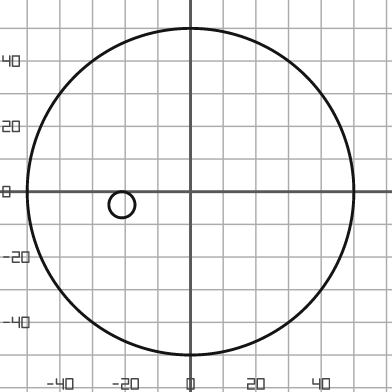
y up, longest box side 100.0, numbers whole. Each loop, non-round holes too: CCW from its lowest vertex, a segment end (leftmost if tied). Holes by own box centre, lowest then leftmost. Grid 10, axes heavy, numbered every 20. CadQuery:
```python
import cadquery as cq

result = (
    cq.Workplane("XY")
    .moveTo(0.0, 0.0)
    .circle(50.0)
    .moveTo(-21.0, -4.0)
    .circle(4.0)
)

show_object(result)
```